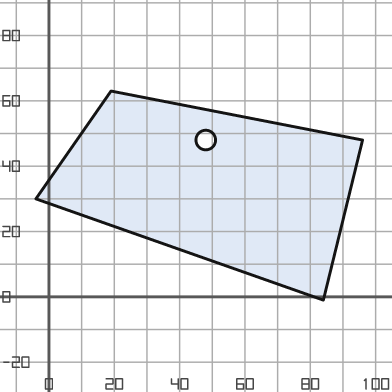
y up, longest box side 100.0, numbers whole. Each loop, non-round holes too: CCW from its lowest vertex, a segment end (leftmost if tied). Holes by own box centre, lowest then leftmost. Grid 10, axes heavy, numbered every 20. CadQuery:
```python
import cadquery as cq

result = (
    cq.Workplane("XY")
    .moveTo(84.0, -1.0)
    .lineTo(96.0, 48.0)
    .lineTo(19.0, 63.0)
    .lineTo(-4.0, 30.0)
    .close()
    .moveTo(48.0, 48.0)
    .circle(3.0)
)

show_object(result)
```